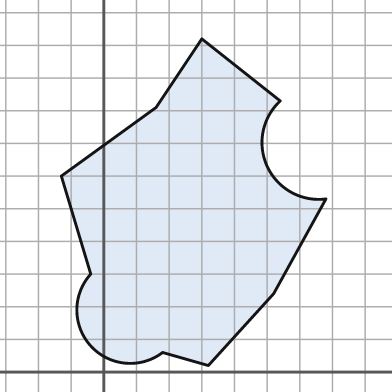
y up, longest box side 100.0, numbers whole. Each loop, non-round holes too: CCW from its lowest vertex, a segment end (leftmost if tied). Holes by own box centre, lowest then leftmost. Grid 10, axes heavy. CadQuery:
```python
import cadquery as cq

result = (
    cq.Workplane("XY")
    .moveTo(32.0, 2.0)
    .lineTo(52.0, 24.0)
    .lineTo(68.0, 53.0)
    .threePointArc((50.0, 63.0), (54.0, 83.0))
    .lineTo(30.0, 102.0)
    .lineTo(16.0, 81.0)
    .lineTo(-13.0, 60.0)
    .lineTo(-4.0, 30.0)
    .threePointArc((-4.0, 8.0), (18.0, 6.0))
    .close()
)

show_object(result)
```